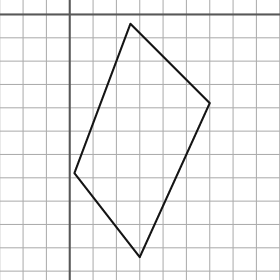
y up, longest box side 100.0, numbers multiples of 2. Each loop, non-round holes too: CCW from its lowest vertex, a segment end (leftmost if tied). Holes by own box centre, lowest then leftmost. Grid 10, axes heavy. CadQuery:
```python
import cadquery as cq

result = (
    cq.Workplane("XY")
    .moveTo(30.0, -104.0)
    .lineTo(60.0, -38.0)
    .lineTo(26.0, -4.0)
    .lineTo(2.0, -68.0)
    .close()
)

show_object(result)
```